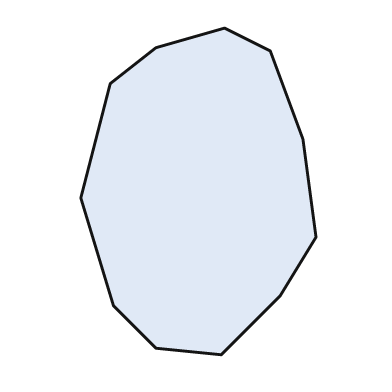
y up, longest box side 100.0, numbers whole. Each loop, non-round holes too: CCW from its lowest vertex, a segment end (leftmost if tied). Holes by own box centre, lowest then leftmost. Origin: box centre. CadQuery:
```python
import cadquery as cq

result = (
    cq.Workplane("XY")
    .moveTo(7.0, -50.0)
    .lineTo(25.0, -32.0)
    .lineTo(36.0, -14.0)
    .lineTo(32.0, 16.0)
    .lineTo(22.0, 43.0)
    .lineTo(8.0, 50.0)
    .lineTo(-13.0, 44.0)
    .lineTo(-27.0, 33.0)
    .lineTo(-36.0, -2.0)
    .lineTo(-26.0, -35.0)
    .lineTo(-13.0, -48.0)
    .close()
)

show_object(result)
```